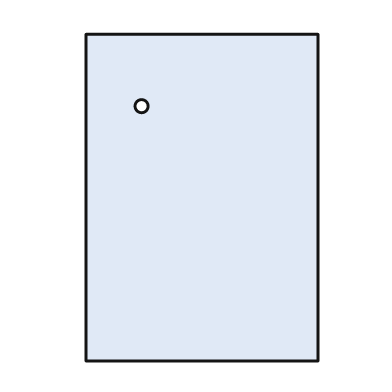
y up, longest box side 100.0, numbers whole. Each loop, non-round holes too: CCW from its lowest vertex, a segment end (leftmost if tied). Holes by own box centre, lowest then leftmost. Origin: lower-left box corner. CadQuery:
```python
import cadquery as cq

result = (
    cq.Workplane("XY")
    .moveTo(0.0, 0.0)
    .lineTo(71.0, 0.0)
    .lineTo(71.0, 100.0)
    .lineTo(0.0, 100.0)
    .close()
    .moveTo(17.0, 78.0)
    .circle(2.0)
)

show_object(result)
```